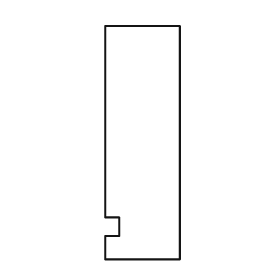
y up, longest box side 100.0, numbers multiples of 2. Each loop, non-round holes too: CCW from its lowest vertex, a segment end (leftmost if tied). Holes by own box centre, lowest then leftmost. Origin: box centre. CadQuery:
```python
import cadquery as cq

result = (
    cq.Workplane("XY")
    .moveTo(-16.0, -50.0)
    .lineTo(16.0, -50.0)
    .lineTo(16.0, 50.0)
    .lineTo(-16.0, 50.0)
    .lineTo(-16.0, -32.0)
    .lineTo(-10.0, -32.0)
    .lineTo(-10.0, -40.0)
    .lineTo(-16.0, -40.0)
    .close()
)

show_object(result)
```